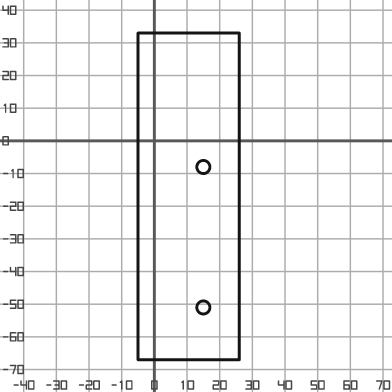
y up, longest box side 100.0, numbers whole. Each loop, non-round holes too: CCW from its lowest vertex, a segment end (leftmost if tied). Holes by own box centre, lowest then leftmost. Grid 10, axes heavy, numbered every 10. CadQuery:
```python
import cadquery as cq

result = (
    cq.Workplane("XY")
    .moveTo(-5.0, -67.0)
    .lineTo(26.0, -67.0)
    .lineTo(26.0, 33.0)
    .lineTo(-5.0, 33.0)
    .close()
    .moveTo(15.0, -51.0)
    .circle(2.0)
    .moveTo(15.0, -8.0)
    .circle(2.0)
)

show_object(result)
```